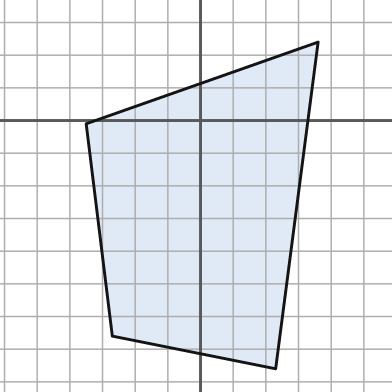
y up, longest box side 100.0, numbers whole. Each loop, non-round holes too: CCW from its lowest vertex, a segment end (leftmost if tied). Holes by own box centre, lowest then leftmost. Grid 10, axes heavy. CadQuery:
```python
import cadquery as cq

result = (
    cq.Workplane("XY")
    .moveTo(23.0, -76.0)
    .lineTo(36.0, 24.0)
    .lineTo(-35.0, -1.0)
    .lineTo(-27.0, -66.0)
    .close()
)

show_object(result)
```